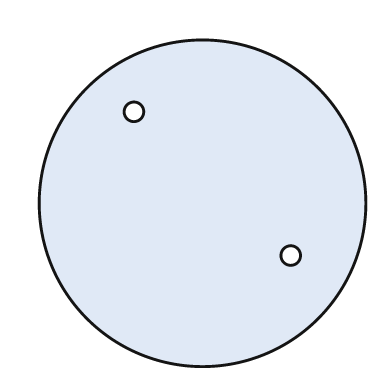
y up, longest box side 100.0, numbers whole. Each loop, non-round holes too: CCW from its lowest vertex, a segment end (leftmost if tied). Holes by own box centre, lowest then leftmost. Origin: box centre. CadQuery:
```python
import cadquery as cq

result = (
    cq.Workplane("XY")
    .moveTo(0.0, 0.0)
    .circle(50.0)
    .moveTo(27.0, -16.0)
    .circle(3.0)
    .moveTo(-21.0, 28.0)
    .circle(3.0)
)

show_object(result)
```